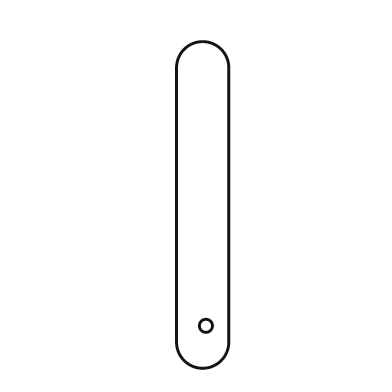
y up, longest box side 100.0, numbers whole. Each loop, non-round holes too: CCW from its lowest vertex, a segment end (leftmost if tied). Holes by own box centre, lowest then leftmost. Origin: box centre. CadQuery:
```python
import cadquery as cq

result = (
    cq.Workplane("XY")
    .moveTo(-8.0, -42.0)
    .threePointArc((0.0, -50.0), (8.0, -42.0))
    .lineTo(8.0, 42.0)
    .threePointArc((0.0, 50.0), (-8.0, 42.0))
    .close()
    .moveTo(1.0, -37.0)
    .circle(2.0)
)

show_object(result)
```